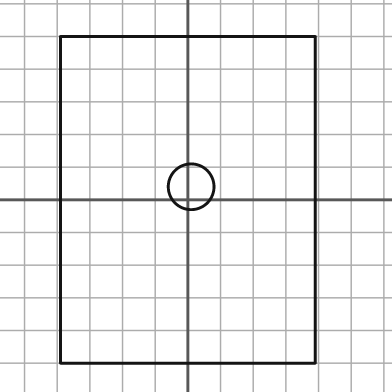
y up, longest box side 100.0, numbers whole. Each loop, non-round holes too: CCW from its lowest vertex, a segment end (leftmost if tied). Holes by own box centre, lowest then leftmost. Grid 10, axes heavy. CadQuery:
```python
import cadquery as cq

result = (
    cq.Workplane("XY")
    .moveTo(-39.0, -50.0)
    .lineTo(39.0, -50.0)
    .lineTo(39.0, 50.0)
    .lineTo(-39.0, 50.0)
    .close()
    .moveTo(1.0, 4.0)
    .circle(7.0)
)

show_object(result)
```